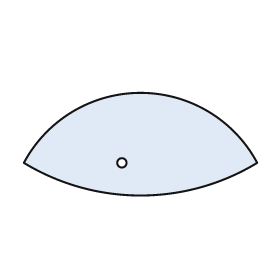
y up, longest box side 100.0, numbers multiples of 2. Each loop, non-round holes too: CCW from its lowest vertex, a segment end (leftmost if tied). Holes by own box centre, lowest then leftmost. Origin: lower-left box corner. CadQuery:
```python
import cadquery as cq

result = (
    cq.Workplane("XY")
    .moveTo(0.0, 14.0)
    .threePointArc((50.0, 0.0), (100.0, 14.0))
    .threePointArc((50.0, 44.0), (0.0, 14.0))
    .close()
    .moveTo(42.0, 14.0)
    .circle(2.0)
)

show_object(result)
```